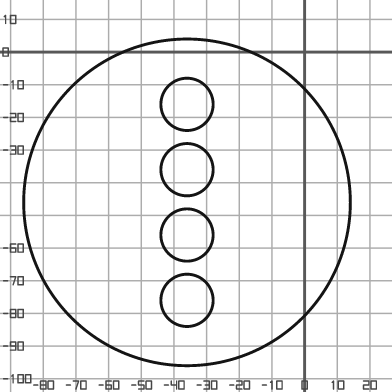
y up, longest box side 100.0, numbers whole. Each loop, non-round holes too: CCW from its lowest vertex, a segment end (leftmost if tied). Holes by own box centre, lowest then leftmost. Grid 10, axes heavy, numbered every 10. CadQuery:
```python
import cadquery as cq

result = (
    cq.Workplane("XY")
    .moveTo(-36.0, -46.0)
    .circle(50.0)
    .moveTo(-36.0, -76.0)
    .circle(8.0)
    .moveTo(-36.0, -56.0)
    .circle(8.0)
    .moveTo(-36.0, -36.0)
    .circle(8.0)
    .moveTo(-36.0, -16.0)
    .circle(8.0)
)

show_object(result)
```